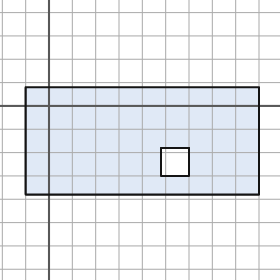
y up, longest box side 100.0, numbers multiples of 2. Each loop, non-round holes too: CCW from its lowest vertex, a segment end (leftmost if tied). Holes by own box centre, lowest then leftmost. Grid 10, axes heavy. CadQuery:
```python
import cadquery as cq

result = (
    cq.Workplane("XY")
    .moveTo(-10.0, -38.0)
    .lineTo(90.0, -38.0)
    .lineTo(90.0, 8.0)
    .lineTo(-10.0, 8.0)
    .close()
    .moveTo(48.0, -30.0)
    .lineTo(60.0, -30.0)
    .lineTo(60.0, -18.0)
    .lineTo(48.0, -18.0)
    .close()
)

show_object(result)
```